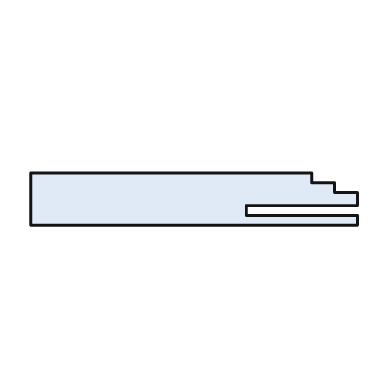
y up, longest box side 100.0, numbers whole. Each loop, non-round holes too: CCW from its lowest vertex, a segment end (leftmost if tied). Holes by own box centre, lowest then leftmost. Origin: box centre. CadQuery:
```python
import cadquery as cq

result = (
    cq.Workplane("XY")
    .moveTo(-50.0, -8.0)
    .lineTo(50.0, -8.0)
    .lineTo(50.0, -5.0)
    .lineTo(16.0, -5.0)
    .lineTo(16.0, -2.0)
    .lineTo(50.0, -2.0)
    .lineTo(50.0, 2.0)
    .lineTo(43.0, 2.0)
    .lineTo(43.0, 5.0)
    .lineTo(36.0, 5.0)
    .lineTo(36.0, 8.0)
    .lineTo(-50.0, 8.0)
    .close()
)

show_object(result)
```